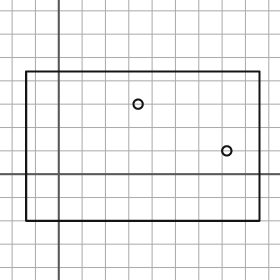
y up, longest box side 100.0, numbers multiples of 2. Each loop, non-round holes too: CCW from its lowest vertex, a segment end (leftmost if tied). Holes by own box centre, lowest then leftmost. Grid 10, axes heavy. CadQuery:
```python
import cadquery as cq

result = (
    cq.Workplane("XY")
    .moveTo(-14.0, -20.0)
    .lineTo(86.0, -20.0)
    .lineTo(86.0, 44.0)
    .lineTo(-14.0, 44.0)
    .close()
    .moveTo(72.0, 10.0)
    .circle(2.0)
    .moveTo(34.0, 30.0)
    .circle(2.0)
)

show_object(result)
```